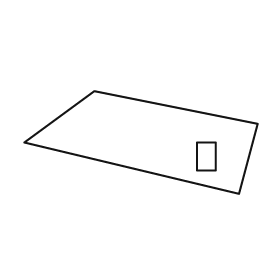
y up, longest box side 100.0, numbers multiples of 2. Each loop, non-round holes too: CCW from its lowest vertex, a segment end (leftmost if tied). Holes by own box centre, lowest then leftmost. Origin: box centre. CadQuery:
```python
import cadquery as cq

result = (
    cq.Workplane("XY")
    .moveTo(42.0, -22.0)
    .lineTo(50.0, 8.0)
    .lineTo(-20.0, 22.0)
    .lineTo(-50.0, 0.0)
    .close()
    .moveTo(24.0, -12.0)
    .lineTo(32.0, -12.0)
    .lineTo(32.0, 0.0)
    .lineTo(24.0, 0.0)
    .close()
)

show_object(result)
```